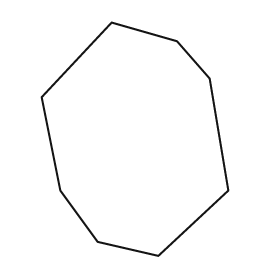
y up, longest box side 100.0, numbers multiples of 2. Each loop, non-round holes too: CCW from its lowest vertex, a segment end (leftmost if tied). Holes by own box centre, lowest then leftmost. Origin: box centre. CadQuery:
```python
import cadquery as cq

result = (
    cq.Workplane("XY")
    .moveTo(10.0, -50.0)
    .lineTo(40.0, -22.0)
    .lineTo(32.0, 26.0)
    .lineTo(18.0, 42.0)
    .lineTo(-10.0, 50.0)
    .lineTo(-40.0, 18.0)
    .lineTo(-32.0, -22.0)
    .lineTo(-16.0, -44.0)
    .close()
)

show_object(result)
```